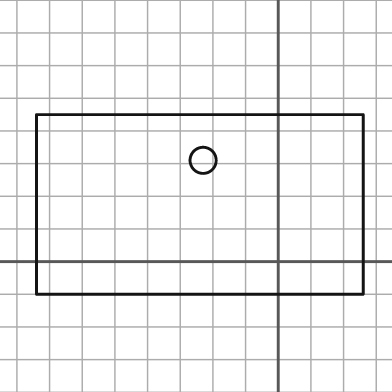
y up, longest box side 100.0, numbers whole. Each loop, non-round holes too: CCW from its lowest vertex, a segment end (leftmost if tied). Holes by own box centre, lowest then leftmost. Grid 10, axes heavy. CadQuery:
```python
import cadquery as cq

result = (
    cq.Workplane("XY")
    .moveTo(-74.0, -10.0)
    .lineTo(26.0, -10.0)
    .lineTo(26.0, 45.0)
    .lineTo(-74.0, 45.0)
    .close()
    .moveTo(-23.0, 31.0)
    .circle(4.0)
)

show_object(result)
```